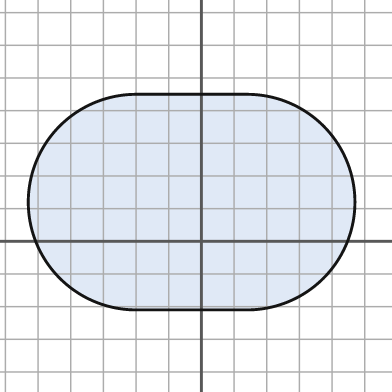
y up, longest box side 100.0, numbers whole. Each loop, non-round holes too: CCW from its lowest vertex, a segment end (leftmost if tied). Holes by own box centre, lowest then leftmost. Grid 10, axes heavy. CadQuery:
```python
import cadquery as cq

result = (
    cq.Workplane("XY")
    .moveTo(-20.0, -21.0)
    .lineTo(14.0, -21.0)
    .threePointArc((47.0, 12.0), (14.0, 45.0))
    .lineTo(-20.0, 45.0)
    .threePointArc((-53.0, 12.0), (-20.0, -21.0))
    .close()
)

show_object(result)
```